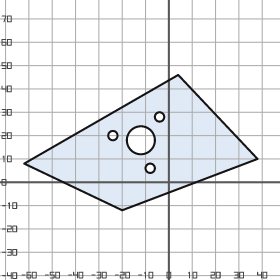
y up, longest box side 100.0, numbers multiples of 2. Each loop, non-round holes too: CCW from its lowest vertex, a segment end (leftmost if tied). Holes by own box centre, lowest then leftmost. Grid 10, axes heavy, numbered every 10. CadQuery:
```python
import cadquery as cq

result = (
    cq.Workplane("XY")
    .moveTo(-20.0, -12.0)
    .lineTo(38.0, 10.0)
    .lineTo(4.0, 46.0)
    .lineTo(-62.0, 8.0)
    .close()
    .moveTo(-8.0, 6.0)
    .circle(2.0)
    .moveTo(-12.0, 18.0)
    .circle(6.0)
    .moveTo(-24.0, 20.0)
    .circle(2.0)
    .moveTo(-4.0, 28.0)
    .circle(2.0)
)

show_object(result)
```